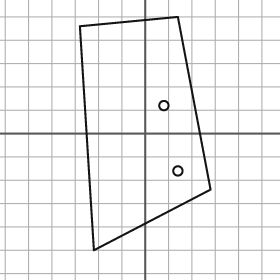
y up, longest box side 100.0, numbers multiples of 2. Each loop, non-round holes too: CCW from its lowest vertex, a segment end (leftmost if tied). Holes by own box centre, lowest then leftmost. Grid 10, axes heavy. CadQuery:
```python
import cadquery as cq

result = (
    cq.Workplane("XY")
    .moveTo(-22.0, -50.0)
    .lineTo(28.0, -24.0)
    .lineTo(14.0, 50.0)
    .lineTo(-28.0, 46.0)
    .close()
    .moveTo(14.0, -16.0)
    .circle(2.0)
    .moveTo(8.0, 12.0)
    .circle(2.0)
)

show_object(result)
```